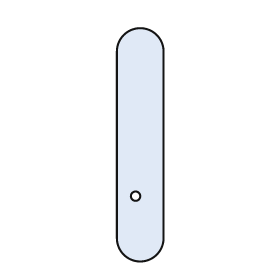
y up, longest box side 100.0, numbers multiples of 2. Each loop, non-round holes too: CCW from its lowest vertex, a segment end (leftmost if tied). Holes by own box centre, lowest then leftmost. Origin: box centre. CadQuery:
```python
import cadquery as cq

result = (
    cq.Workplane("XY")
    .moveTo(-10.0, -40.0)
    .threePointArc((0.0, -50.0), (10.0, -40.0))
    .lineTo(10.0, 40.0)
    .threePointArc((0.0, 50.0), (-10.0, 40.0))
    .close()
    .moveTo(-2.0, -22.0)
    .circle(2.0)
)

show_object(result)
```